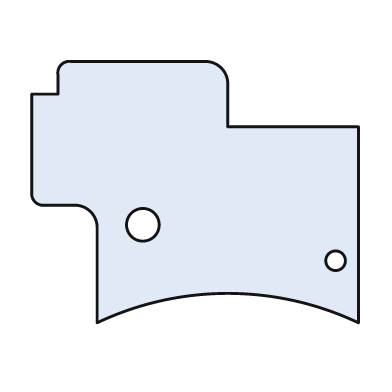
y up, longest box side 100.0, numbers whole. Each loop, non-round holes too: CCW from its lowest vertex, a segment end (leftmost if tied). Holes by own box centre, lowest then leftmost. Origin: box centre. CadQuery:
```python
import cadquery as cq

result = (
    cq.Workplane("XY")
    .moveTo(-30.0, -40.0)
    .threePointArc((10.0, -31.0), (50.0, -40.0))
    .lineTo(50.0, 20.0)
    .lineTo(10.0, 20.0)
    .lineTo(10.0, 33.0)
    .threePointArc((8.0, 38.0), (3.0, 40.0))
    .lineTo(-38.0, 40.0)
    .threePointArc((-41.0, 39.0), (-42.0, 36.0))
    .lineTo(-42.0, 30.0)
    .lineTo(-50.0, 30.0)
    .lineTo(-50.0, 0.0)
    .threePointArc((-49.0, -3.0), (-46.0, -4.0))
    .lineTo(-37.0, -4.0)
    .threePointArc((-32.0, -6.0), (-30.0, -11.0))
    .close()
    .moveTo(43.0, -21.0)
    .circle(3.0)
    .moveTo(-16.0, -10.0)
    .circle(5.0)
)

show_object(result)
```